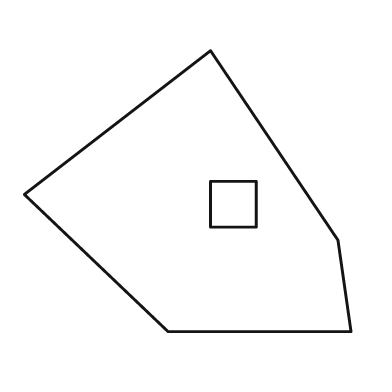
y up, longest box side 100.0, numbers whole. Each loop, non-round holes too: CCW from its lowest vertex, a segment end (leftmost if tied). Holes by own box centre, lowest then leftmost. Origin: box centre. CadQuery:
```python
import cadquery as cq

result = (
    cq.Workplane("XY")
    .moveTo(-6.0, -43.0)
    .lineTo(50.0, -43.0)
    .lineTo(46.0, -15.0)
    .lineTo(7.0, 43.0)
    .lineTo(-50.0, -1.0)
    .close()
    .moveTo(7.0, -11.0)
    .lineTo(21.0, -11.0)
    .lineTo(21.0, 3.0)
    .lineTo(7.0, 3.0)
    .close()
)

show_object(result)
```